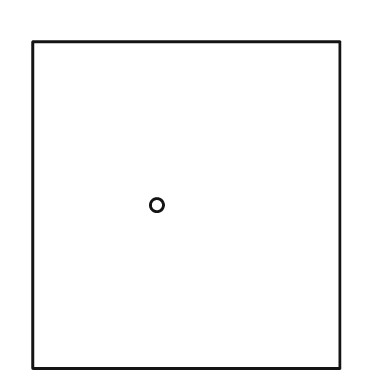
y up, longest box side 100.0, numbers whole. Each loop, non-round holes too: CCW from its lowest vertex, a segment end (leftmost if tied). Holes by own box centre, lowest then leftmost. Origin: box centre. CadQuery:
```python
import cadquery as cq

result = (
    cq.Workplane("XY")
    .moveTo(-47.0, -50.0)
    .lineTo(47.0, -50.0)
    .lineTo(47.0, 50.0)
    .lineTo(-47.0, 50.0)
    .close()
    .moveTo(-9.0, 0.0)
    .circle(2.0)
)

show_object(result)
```